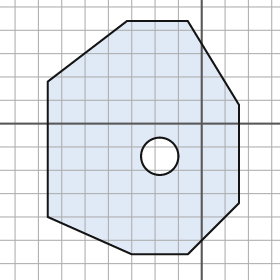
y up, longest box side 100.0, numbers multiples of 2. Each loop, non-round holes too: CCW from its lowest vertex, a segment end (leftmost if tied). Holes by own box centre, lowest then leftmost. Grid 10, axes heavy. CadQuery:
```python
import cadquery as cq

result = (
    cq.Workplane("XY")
    .moveTo(-30.0, -56.0)
    .lineTo(-6.0, -56.0)
    .lineTo(16.0, -34.0)
    .lineTo(16.0, 8.0)
    .lineTo(-6.0, 44.0)
    .lineTo(-32.0, 44.0)
    .lineTo(-66.0, 18.0)
    .lineTo(-66.0, -40.0)
    .close()
    .moveTo(-18.0, -14.0)
    .circle(8.0)
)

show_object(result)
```